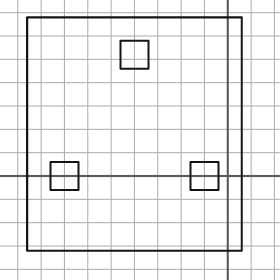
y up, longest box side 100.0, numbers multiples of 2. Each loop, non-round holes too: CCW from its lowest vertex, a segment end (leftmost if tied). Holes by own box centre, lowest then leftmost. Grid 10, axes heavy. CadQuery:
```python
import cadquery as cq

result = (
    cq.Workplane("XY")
    .moveTo(-86.0, -32.0)
    .lineTo(6.0, -32.0)
    .lineTo(6.0, 68.0)
    .lineTo(-86.0, 68.0)
    .close()
    .moveTo(-76.0, -6.0)
    .lineTo(-64.0, -6.0)
    .lineTo(-64.0, 6.0)
    .lineTo(-76.0, 6.0)
    .close()
    .moveTo(-16.0, -6.0)
    .lineTo(-4.0, -6.0)
    .lineTo(-4.0, 6.0)
    .lineTo(-16.0, 6.0)
    .close()
    .moveTo(-46.0, 46.0)
    .lineTo(-34.0, 46.0)
    .lineTo(-34.0, 58.0)
    .lineTo(-46.0, 58.0)
    .close()
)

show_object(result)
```